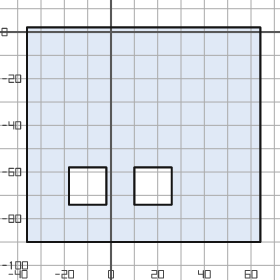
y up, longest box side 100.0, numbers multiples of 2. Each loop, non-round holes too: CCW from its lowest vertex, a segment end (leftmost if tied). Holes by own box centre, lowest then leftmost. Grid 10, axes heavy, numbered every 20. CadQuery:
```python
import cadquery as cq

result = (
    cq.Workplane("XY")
    .moveTo(-36.0, -90.0)
    .lineTo(64.0, -90.0)
    .lineTo(64.0, 2.0)
    .lineTo(-36.0, 2.0)
    .close()
    .moveTo(-18.0, -74.0)
    .lineTo(-2.0, -74.0)
    .lineTo(-2.0, -58.0)
    .lineTo(-18.0, -58.0)
    .close()
    .moveTo(10.0, -74.0)
    .lineTo(26.0, -74.0)
    .lineTo(26.0, -58.0)
    .lineTo(10.0, -58.0)
    .close()
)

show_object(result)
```